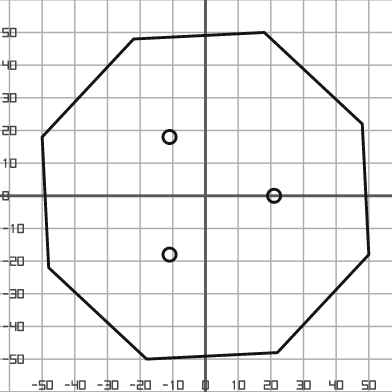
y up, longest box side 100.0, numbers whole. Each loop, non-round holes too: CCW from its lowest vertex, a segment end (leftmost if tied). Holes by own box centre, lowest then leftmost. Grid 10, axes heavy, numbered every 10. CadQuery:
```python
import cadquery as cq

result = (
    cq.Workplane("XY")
    .moveTo(-18.0, -50.0)
    .lineTo(22.0, -48.0)
    .lineTo(50.0, -18.0)
    .lineTo(48.0, 22.0)
    .lineTo(18.0, 50.0)
    .lineTo(-22.0, 48.0)
    .lineTo(-50.0, 18.0)
    .lineTo(-48.0, -22.0)
    .close()
    .moveTo(-11.0, -18.0)
    .circle(2.0)
    .moveTo(21.0, 0.0)
    .circle(2.0)
    .moveTo(-11.0, 18.0)
    .circle(2.0)
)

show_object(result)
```